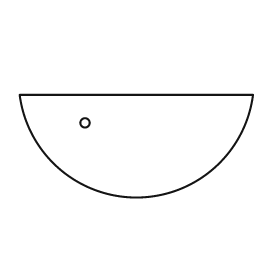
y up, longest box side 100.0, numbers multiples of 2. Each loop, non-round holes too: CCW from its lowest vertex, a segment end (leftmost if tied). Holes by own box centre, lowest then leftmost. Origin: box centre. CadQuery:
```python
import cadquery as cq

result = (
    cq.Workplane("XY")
    .moveTo(-50.0, 22.0)
    .threePointArc((0.0, -22.0), (50.0, 22.0))
    .close()
    .moveTo(-22.0, 10.0)
    .circle(2.0)
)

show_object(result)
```